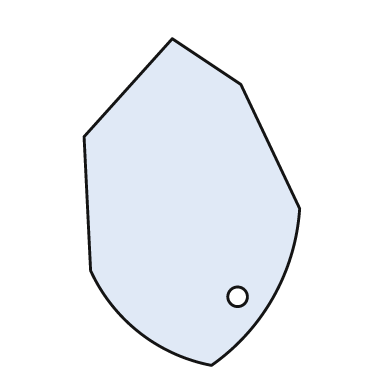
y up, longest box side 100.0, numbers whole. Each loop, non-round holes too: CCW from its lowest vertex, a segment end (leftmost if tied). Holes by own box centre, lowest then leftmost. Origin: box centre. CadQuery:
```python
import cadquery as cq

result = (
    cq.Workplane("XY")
    .moveTo(6.0, -50.0)
    .threePointArc((25.0, -29.0), (33.0, -2.0))
    .lineTo(15.0, 36.0)
    .lineTo(-6.0, 50.0)
    .lineTo(-33.0, 20.0)
    .lineTo(-31.0, -21.0)
    .threePointArc((-16.0, -40.0), (6.0, -50.0))
    .close()
    .moveTo(14.0, -29.0)
    .circle(3.0)
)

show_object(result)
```